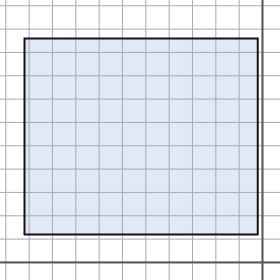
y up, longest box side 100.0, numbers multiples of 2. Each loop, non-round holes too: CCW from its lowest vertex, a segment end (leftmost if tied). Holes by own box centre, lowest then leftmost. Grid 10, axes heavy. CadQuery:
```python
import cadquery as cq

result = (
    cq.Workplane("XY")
    .moveTo(-102.0, 12.0)
    .lineTo(-2.0, 12.0)
    .lineTo(-2.0, 96.0)
    .lineTo(-102.0, 96.0)
    .close()
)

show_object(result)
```